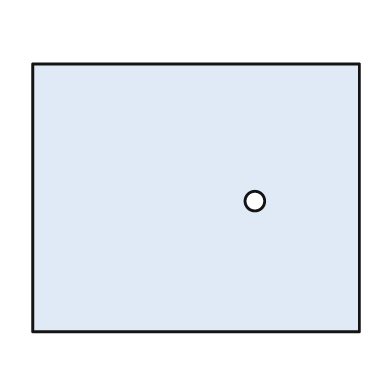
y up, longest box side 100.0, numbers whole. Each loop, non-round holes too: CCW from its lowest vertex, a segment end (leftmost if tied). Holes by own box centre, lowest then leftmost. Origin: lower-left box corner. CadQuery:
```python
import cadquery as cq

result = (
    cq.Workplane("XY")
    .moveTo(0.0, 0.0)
    .lineTo(100.0, 0.0)
    .lineTo(100.0, 82.0)
    .lineTo(0.0, 82.0)
    .close()
    .moveTo(68.0, 40.0)
    .circle(3.0)
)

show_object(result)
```